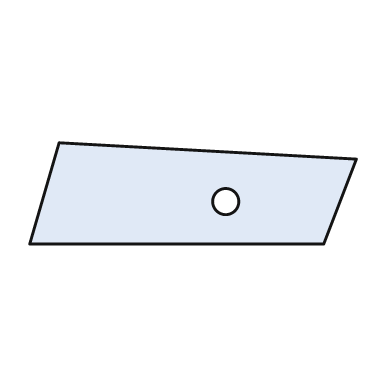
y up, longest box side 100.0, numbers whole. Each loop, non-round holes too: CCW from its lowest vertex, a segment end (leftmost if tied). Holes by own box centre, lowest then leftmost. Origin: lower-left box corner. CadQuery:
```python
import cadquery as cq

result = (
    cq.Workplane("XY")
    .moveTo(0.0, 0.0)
    .lineTo(90.0, 0.0)
    .lineTo(100.0, 26.0)
    .lineTo(9.0, 31.0)
    .close()
    .moveTo(60.0, 13.0)
    .circle(4.0)
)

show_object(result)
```